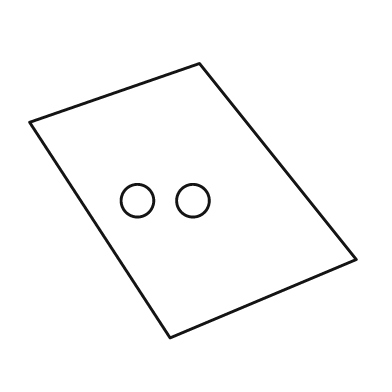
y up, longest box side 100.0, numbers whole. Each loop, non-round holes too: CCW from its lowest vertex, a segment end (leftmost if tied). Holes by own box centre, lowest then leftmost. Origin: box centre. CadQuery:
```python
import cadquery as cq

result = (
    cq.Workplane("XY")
    .moveTo(-7.0, -42.0)
    .lineTo(50.0, -18.0)
    .lineTo(2.0, 42.0)
    .lineTo(-50.0, 24.0)
    .close()
    .moveTo(-17.0, 0.0)
    .circle(5.0)
    .moveTo(0.0, 0.0)
    .circle(5.0)
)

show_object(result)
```